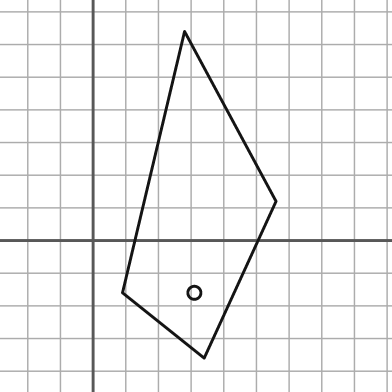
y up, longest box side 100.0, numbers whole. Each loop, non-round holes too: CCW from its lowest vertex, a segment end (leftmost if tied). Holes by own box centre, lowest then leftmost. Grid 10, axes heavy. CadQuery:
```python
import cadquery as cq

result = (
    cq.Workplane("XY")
    .moveTo(34.0, -36.0)
    .lineTo(56.0, 12.0)
    .lineTo(28.0, 64.0)
    .lineTo(9.0, -16.0)
    .close()
    .moveTo(31.0, -16.0)
    .circle(2.0)
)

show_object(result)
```